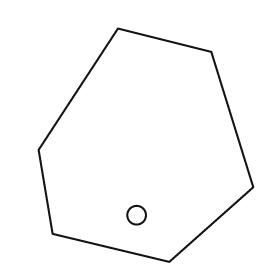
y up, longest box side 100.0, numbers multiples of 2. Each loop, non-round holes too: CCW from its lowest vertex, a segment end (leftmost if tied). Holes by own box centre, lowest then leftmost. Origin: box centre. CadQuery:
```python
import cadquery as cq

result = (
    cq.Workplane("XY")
    .moveTo(10.0, -50.0)
    .lineTo(46.0, -18.0)
    .lineTo(28.0, 40.0)
    .lineTo(-12.0, 50.0)
    .lineTo(-46.0, -2.0)
    .lineTo(-40.0, -38.0)
    .close()
    .moveTo(-4.0, -30.0)
    .circle(4.0)
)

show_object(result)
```